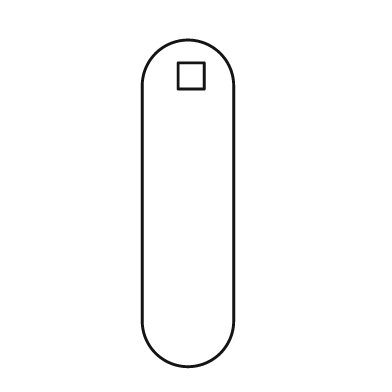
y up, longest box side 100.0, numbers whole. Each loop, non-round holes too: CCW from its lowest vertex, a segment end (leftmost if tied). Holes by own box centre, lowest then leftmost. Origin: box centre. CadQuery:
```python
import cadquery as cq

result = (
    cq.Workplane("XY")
    .moveTo(-14.0, -36.0)
    .threePointArc((0.0, -50.0), (14.0, -36.0))
    .lineTo(14.0, 36.0)
    .threePointArc((0.0, 50.0), (-14.0, 36.0))
    .close()
    .moveTo(-3.0, 35.0)
    .lineTo(5.0, 35.0)
    .lineTo(5.0, 43.0)
    .lineTo(-3.0, 43.0)
    .close()
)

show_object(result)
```